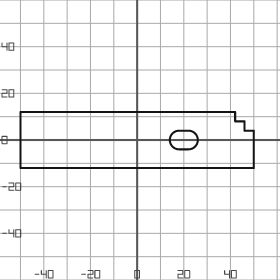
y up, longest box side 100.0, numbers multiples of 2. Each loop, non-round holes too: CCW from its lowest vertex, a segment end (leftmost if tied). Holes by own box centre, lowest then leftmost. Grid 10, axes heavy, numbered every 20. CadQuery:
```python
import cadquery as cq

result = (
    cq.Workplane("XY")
    .moveTo(-50.0, -12.0)
    .lineTo(50.0, -12.0)
    .lineTo(50.0, 4.0)
    .lineTo(46.0, 4.0)
    .lineTo(46.0, 8.0)
    .lineTo(42.0, 8.0)
    .lineTo(42.0, 12.0)
    .lineTo(-50.0, 12.0)
    .close()
    .moveTo(18.0, -4.0)
    .lineTo(22.0, -4.0)
    .threePointArc((26.0, 0.0), (22.0, 4.0))
    .lineTo(18.0, 4.0)
    .threePointArc((14.0, 0.0), (18.0, -4.0))
    .close()
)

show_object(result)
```